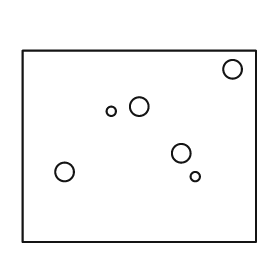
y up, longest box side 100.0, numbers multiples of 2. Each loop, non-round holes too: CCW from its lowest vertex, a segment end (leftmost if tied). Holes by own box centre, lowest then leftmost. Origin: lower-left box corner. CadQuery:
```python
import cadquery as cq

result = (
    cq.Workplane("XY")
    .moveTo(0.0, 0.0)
    .lineTo(100.0, 0.0)
    .lineTo(100.0, 82.0)
    .lineTo(0.0, 82.0)
    .close()
    .moveTo(74.0, 28.0)
    .circle(2.0)
    .moveTo(18.0, 30.0)
    .circle(4.0)
    .moveTo(68.0, 38.0)
    .circle(4.0)
    .moveTo(38.0, 56.0)
    .circle(2.0)
    .moveTo(50.0, 58.0)
    .circle(4.0)
    .moveTo(90.0, 74.0)
    .circle(4.0)
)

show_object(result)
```